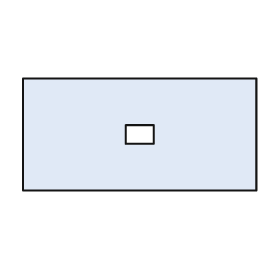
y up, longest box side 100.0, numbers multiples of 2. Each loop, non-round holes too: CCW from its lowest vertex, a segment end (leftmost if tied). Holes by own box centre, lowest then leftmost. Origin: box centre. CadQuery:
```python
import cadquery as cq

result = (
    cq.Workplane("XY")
    .moveTo(-50.0, -24.0)
    .lineTo(50.0, -24.0)
    .lineTo(50.0, 24.0)
    .lineTo(-50.0, 24.0)
    .close()
    .moveTo(-6.0, -4.0)
    .lineTo(6.0, -4.0)
    .lineTo(6.0, 4.0)
    .lineTo(-6.0, 4.0)
    .close()
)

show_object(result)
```